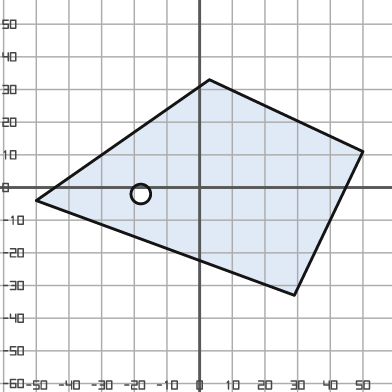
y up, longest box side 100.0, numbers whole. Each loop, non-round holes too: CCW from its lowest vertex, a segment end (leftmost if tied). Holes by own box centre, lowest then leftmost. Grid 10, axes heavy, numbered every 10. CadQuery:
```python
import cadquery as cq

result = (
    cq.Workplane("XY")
    .moveTo(29.0, -33.0)
    .lineTo(50.0, 11.0)
    .lineTo(3.0, 33.0)
    .lineTo(-50.0, -4.0)
    .close()
    .moveTo(-18.0, -2.0)
    .circle(3.0)
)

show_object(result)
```